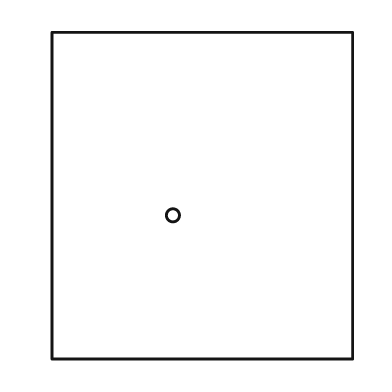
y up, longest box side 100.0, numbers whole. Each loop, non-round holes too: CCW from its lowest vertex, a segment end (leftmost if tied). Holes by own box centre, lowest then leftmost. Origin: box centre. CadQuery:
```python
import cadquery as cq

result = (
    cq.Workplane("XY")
    .moveTo(-46.0, -50.0)
    .lineTo(46.0, -50.0)
    .lineTo(46.0, 50.0)
    .lineTo(-46.0, 50.0)
    .close()
    .moveTo(-9.0, -6.0)
    .circle(2.0)
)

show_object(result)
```